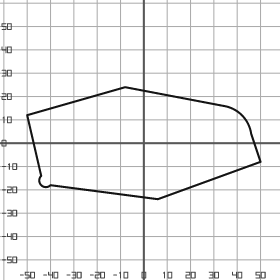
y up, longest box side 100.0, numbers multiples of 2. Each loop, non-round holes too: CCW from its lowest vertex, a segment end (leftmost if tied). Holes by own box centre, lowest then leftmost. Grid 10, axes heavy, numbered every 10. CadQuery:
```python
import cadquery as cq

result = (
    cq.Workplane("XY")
    .moveTo(6.0, -24.0)
    .lineTo(50.0, -8.0)
    .lineTo(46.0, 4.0)
    .threePointArc((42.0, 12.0), (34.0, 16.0))
    .lineTo(-8.0, 24.0)
    .lineTo(-50.0, 12.0)
    .lineTo(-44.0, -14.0)
    .threePointArc((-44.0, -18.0), (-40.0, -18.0))
    .close()
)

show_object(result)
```